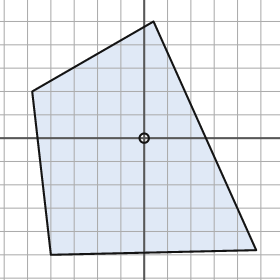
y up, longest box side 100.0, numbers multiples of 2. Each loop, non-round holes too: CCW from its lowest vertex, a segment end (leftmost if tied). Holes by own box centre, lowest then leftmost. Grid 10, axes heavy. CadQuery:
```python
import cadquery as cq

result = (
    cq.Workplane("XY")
    .moveTo(-40.0, -50.0)
    .lineTo(48.0, -48.0)
    .lineTo(4.0, 50.0)
    .lineTo(-48.0, 20.0)
    .close()
    .moveTo(0.0, 0.0)
    .circle(2.0)
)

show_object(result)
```